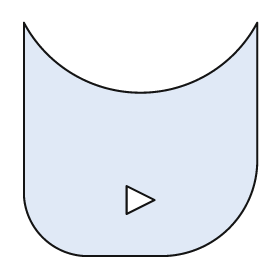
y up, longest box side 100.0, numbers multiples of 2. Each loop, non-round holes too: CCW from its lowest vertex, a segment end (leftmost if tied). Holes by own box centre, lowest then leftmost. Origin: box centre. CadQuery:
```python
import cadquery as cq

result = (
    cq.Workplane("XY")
    .moveTo(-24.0, -50.0)
    .lineTo(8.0, -50.0)
    .threePointArc((38.0, -38.0), (50.0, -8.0))
    .lineTo(50.0, 50.0)
    .threePointArc((0.0, 20.0), (-50.0, 50.0))
    .lineTo(-50.0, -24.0)
    .threePointArc((-42.0, -42.0), (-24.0, -50.0))
    .close()
    .moveTo(-6.0, -32.0)
    .lineTo(6.0, -26.0)
    .lineTo(-6.0, -20.0)
    .close()
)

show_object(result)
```